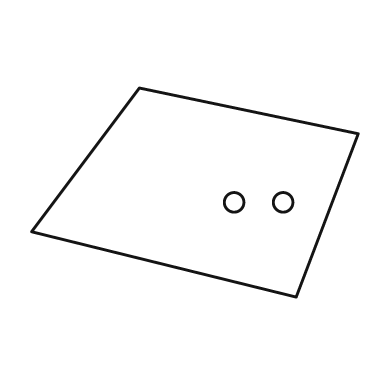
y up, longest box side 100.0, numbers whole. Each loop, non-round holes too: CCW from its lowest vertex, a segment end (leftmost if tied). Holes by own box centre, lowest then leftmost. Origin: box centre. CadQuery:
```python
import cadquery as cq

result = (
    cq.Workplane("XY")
    .moveTo(31.0, -32.0)
    .lineTo(50.0, 18.0)
    .lineTo(-17.0, 32.0)
    .lineTo(-50.0, -12.0)
    .close()
    .moveTo(12.0, -3.0)
    .circle(3.0)
    .moveTo(27.0, -3.0)
    .circle(3.0)
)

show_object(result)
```